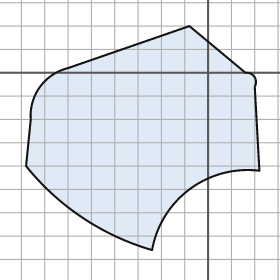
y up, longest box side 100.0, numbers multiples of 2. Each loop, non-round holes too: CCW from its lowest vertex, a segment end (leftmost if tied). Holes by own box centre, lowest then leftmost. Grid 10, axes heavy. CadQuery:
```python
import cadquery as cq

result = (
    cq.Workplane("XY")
    .moveTo(-24.0, -76.0)
    .threePointArc((-8.0, -50.0), (22.0, -42.0))
    .lineTo(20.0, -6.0)
    .threePointArc((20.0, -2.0), (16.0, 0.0))
    .lineTo(-8.0, 20.0)
    .lineTo(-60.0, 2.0)
    .threePointArc((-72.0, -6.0), (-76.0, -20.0))
    .lineTo(-78.0, -40.0)
    .threePointArc((-54.0, -62.0), (-24.0, -76.0))
    .close()
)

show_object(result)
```